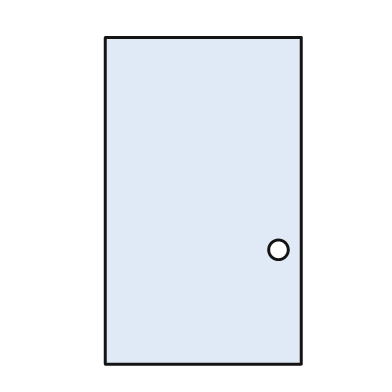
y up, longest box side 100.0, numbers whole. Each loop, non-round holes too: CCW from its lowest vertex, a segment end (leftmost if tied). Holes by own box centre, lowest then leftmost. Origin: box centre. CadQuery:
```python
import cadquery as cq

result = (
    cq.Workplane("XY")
    .moveTo(-30.0, -50.0)
    .lineTo(30.0, -50.0)
    .lineTo(30.0, 50.0)
    .lineTo(-30.0, 50.0)
    .close()
    .moveTo(23.0, -15.0)
    .circle(3.0)
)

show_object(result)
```